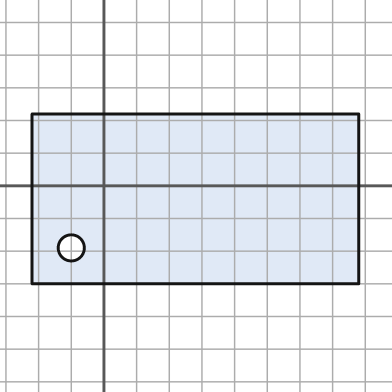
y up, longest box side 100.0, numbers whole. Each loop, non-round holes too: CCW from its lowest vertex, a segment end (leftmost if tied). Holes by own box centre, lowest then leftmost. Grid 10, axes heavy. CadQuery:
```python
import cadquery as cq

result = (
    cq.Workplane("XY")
    .moveTo(-22.0, -30.0)
    .lineTo(78.0, -30.0)
    .lineTo(78.0, 22.0)
    .lineTo(-22.0, 22.0)
    .close()
    .moveTo(-10.0, -19.0)
    .circle(4.0)
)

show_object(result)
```